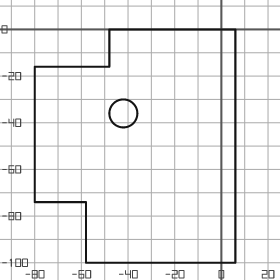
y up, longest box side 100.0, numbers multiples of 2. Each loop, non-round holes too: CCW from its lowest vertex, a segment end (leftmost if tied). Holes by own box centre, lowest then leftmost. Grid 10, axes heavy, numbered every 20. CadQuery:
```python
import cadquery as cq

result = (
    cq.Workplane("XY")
    .moveTo(-58.0, -100.0)
    .lineTo(6.0, -100.0)
    .lineTo(6.0, 0.0)
    .lineTo(-48.0, 0.0)
    .lineTo(-48.0, -16.0)
    .lineTo(-80.0, -16.0)
    .lineTo(-80.0, -74.0)
    .lineTo(-58.0, -74.0)
    .close()
    .moveTo(-42.0, -36.0)
    .circle(6.0)
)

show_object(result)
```